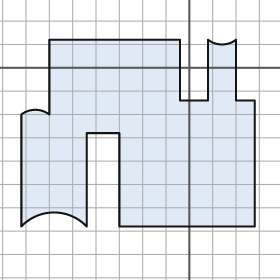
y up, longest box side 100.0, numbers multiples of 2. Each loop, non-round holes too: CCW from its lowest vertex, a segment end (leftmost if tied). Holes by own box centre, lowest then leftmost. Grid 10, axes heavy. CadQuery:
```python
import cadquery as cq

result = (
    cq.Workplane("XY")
    .moveTo(-72.0, -68.0)
    .threePointArc((-58.0, -62.0), (-44.0, -68.0))
    .lineTo(-44.0, -28.0)
    .lineTo(-30.0, -28.0)
    .lineTo(-30.0, -68.0)
    .lineTo(28.0, -68.0)
    .lineTo(28.0, -14.0)
    .lineTo(20.0, -14.0)
    .lineTo(20.0, 12.0)
    .threePointArc((14.0, 10.0), (8.0, 12.0))
    .lineTo(8.0, -14.0)
    .lineTo(-4.0, -14.0)
    .lineTo(-4.0, 12.0)
    .lineTo(-60.0, 12.0)
    .lineTo(-60.0, -20.0)
    .threePointArc((-66.0, -18.0), (-72.0, -20.0))
    .close()
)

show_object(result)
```